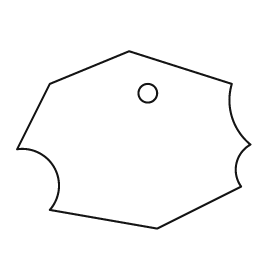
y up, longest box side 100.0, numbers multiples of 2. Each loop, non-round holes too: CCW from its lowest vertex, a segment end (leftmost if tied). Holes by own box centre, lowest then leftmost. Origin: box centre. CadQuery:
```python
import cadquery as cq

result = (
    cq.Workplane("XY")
    .moveTo(10.0, -38.0)
    .lineTo(46.0, -20.0)
    .threePointArc((44.0, -10.0), (50.0, -2.0))
    .threePointArc((42.0, 10.0), (42.0, 24.0))
    .lineTo(-2.0, 38.0)
    .lineTo(-36.0, 24.0)
    .lineTo(-50.0, -4.0)
    .threePointArc((-34.0, -12.0), (-36.0, -30.0))
    .close()
    .moveTo(6.0, 20.0)
    .circle(4.0)
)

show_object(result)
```